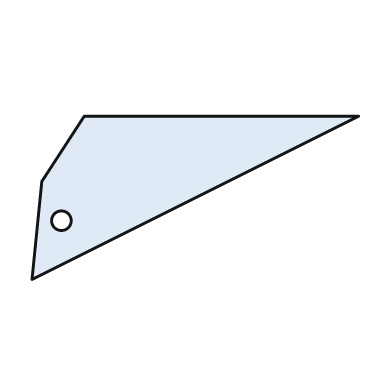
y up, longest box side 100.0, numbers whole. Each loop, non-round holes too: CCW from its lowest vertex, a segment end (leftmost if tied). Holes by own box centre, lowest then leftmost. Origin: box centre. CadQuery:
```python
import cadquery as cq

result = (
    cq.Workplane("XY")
    .moveTo(-50.0, -25.0)
    .lineTo(50.0, 25.0)
    .lineTo(-34.0, 25.0)
    .lineTo(-47.0, 5.0)
    .close()
    .moveTo(-41.0, -7.0)
    .circle(3.0)
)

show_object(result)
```